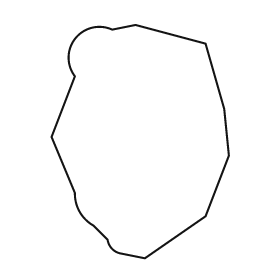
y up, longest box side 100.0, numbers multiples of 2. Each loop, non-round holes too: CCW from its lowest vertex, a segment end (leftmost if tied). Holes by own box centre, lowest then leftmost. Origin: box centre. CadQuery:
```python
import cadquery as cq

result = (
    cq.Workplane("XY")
    .moveTo(2.0, -50.0)
    .lineTo(28.0, -32.0)
    .lineTo(38.0, -6.0)
    .lineTo(36.0, 14.0)
    .lineTo(28.0, 42.0)
    .lineTo(-2.0, 50.0)
    .lineTo(-12.0, 48.0)
    .threePointArc((-28.0, 44.0), (-28.0, 28.0))
    .lineTo(-38.0, 2.0)
    .lineTo(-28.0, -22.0)
    .threePointArc((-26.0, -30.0), (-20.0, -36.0))
    .lineTo(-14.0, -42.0)
    .threePointArc((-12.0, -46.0), (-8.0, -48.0))
    .close()
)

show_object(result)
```